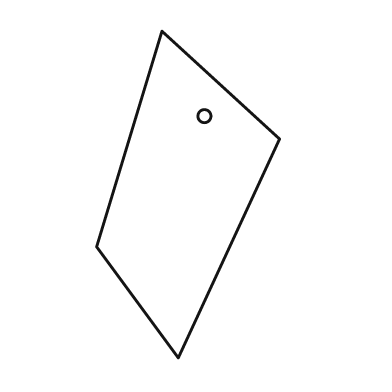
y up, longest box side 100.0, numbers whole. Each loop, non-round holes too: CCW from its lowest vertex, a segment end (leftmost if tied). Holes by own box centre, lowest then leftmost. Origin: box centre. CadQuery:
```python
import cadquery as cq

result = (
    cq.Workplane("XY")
    .moveTo(-3.0, -50.0)
    .lineTo(28.0, 17.0)
    .lineTo(-8.0, 50.0)
    .lineTo(-28.0, -16.0)
    .close()
    .moveTo(5.0, 24.0)
    .circle(2.0)
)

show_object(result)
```